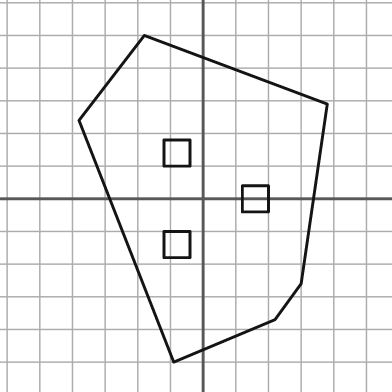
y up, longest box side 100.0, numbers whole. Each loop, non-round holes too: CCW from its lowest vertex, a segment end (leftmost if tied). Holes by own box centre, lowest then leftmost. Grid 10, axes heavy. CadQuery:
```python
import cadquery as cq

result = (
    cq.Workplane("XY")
    .moveTo(-9.0, -50.0)
    .lineTo(22.0, -37.0)
    .lineTo(30.0, -26.0)
    .lineTo(38.0, 29.0)
    .lineTo(-18.0, 50.0)
    .lineTo(-38.0, 24.0)
    .close()
    .moveTo(-12.0, -18.0)
    .lineTo(-4.0, -18.0)
    .lineTo(-4.0, -10.0)
    .lineTo(-12.0, -10.0)
    .close()
    .moveTo(12.0, -4.0)
    .lineTo(20.0, -4.0)
    .lineTo(20.0, 4.0)
    .lineTo(12.0, 4.0)
    .close()
    .moveTo(-12.0, 10.0)
    .lineTo(-4.0, 10.0)
    .lineTo(-4.0, 18.0)
    .lineTo(-12.0, 18.0)
    .close()
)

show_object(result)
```